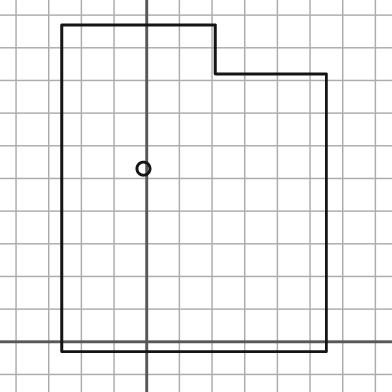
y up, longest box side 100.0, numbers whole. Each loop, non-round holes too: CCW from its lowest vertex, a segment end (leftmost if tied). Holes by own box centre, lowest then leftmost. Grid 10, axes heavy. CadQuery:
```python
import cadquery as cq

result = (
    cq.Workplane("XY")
    .moveTo(-26.0, -3.0)
    .lineTo(55.0, -3.0)
    .lineTo(55.0, 82.0)
    .lineTo(21.0, 82.0)
    .lineTo(21.0, 97.0)
    .lineTo(-26.0, 97.0)
    .close()
    .moveTo(-1.0, 53.0)
    .circle(2.0)
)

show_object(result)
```